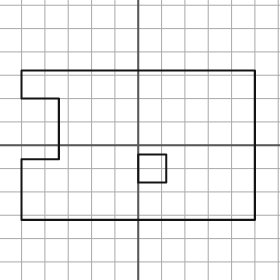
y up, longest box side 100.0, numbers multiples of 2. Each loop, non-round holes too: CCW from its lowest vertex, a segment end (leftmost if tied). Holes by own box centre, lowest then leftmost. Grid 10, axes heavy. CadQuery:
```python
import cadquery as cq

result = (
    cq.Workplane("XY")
    .moveTo(-50.0, -32.0)
    .lineTo(50.0, -32.0)
    .lineTo(50.0, 32.0)
    .lineTo(-50.0, 32.0)
    .lineTo(-50.0, 20.0)
    .lineTo(-34.0, 20.0)
    .lineTo(-34.0, -6.0)
    .lineTo(-50.0, -6.0)
    .close()
    .moveTo(0.0, -16.0)
    .lineTo(12.0, -16.0)
    .lineTo(12.0, -4.0)
    .lineTo(0.0, -4.0)
    .close()
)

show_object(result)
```